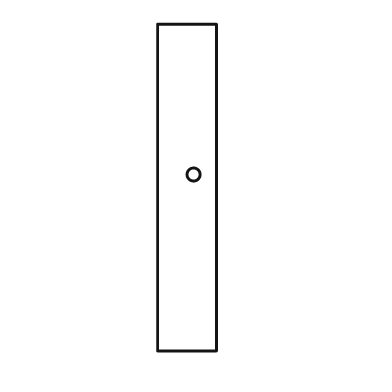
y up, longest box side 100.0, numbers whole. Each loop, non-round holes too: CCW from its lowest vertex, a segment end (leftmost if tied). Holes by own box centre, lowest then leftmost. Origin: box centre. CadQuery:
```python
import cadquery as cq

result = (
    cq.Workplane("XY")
    .moveTo(-9.0, -50.0)
    .lineTo(9.0, -50.0)
    .lineTo(9.0, 50.0)
    .lineTo(-9.0, 50.0)
    .close()
    .moveTo(2.0, 4.0)
    .circle(2.0)
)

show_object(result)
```